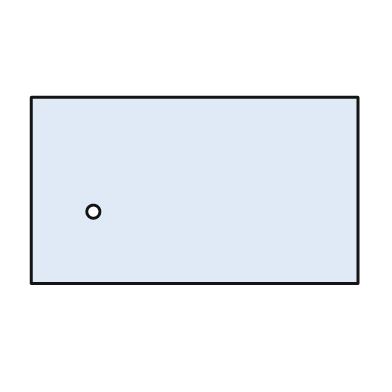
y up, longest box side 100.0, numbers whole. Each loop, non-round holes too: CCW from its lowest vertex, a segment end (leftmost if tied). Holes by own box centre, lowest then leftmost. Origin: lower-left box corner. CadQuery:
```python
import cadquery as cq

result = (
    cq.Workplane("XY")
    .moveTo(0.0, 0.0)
    .lineTo(100.0, 0.0)
    .lineTo(100.0, 57.0)
    .lineTo(0.0, 57.0)
    .close()
    .moveTo(19.0, 22.0)
    .circle(2.0)
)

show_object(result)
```